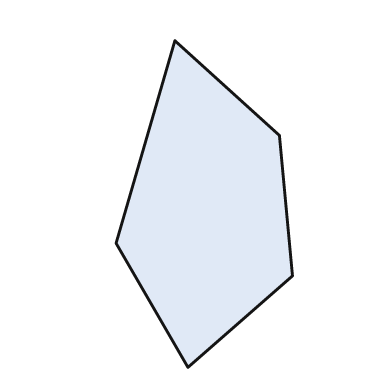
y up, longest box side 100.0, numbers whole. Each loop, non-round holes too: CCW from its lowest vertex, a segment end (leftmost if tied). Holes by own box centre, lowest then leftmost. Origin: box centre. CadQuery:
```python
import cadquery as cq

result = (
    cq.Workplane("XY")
    .moveTo(-5.0, -50.0)
    .lineTo(27.0, -22.0)
    .lineTo(23.0, 21.0)
    .lineTo(-9.0, 50.0)
    .lineTo(-27.0, -12.0)
    .close()
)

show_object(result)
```